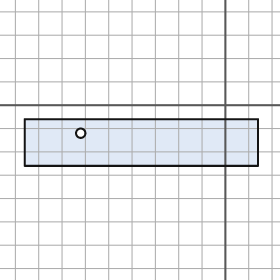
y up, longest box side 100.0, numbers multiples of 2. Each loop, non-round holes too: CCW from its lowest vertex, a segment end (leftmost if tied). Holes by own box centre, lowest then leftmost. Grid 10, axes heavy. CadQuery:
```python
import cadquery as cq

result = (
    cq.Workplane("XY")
    .moveTo(-86.0, -26.0)
    .lineTo(14.0, -26.0)
    .lineTo(14.0, -6.0)
    .lineTo(-86.0, -6.0)
    .close()
    .moveTo(-62.0, -12.0)
    .circle(2.0)
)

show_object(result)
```